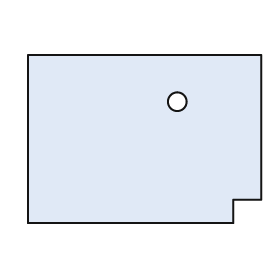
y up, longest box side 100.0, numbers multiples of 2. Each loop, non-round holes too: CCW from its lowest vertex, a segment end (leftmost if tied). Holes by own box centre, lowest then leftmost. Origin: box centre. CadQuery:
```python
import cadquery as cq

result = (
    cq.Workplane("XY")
    .moveTo(-50.0, -36.0)
    .lineTo(38.0, -36.0)
    .lineTo(38.0, -26.0)
    .lineTo(50.0, -26.0)
    .lineTo(50.0, 36.0)
    .lineTo(-50.0, 36.0)
    .close()
    .moveTo(14.0, 16.0)
    .circle(4.0)
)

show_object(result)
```